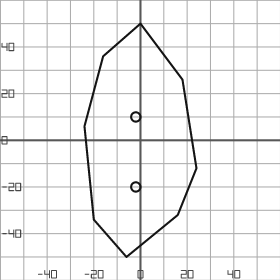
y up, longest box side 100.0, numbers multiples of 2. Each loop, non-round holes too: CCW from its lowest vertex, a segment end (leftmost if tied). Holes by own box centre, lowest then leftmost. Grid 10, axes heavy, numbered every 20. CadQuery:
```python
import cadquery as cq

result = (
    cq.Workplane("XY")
    .moveTo(-6.0, -50.0)
    .lineTo(16.0, -32.0)
    .lineTo(24.0, -12.0)
    .lineTo(18.0, 26.0)
    .lineTo(0.0, 50.0)
    .lineTo(-16.0, 36.0)
    .lineTo(-24.0, 6.0)
    .lineTo(-20.0, -34.0)
    .close()
    .moveTo(-2.0, -20.0)
    .circle(2.0)
    .moveTo(-2.0, 10.0)
    .circle(2.0)
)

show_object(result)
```